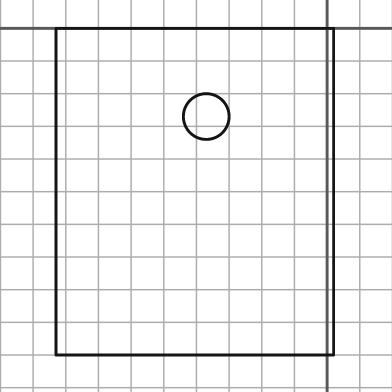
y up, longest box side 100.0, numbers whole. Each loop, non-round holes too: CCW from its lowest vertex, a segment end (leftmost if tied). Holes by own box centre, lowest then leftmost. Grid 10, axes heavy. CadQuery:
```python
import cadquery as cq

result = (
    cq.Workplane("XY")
    .moveTo(-83.0, -100.0)
    .lineTo(2.0, -100.0)
    .lineTo(2.0, 0.0)
    .lineTo(-83.0, 0.0)
    .close()
    .moveTo(-37.0, -27.0)
    .circle(7.0)
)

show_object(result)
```